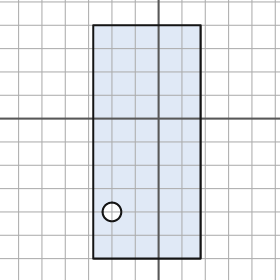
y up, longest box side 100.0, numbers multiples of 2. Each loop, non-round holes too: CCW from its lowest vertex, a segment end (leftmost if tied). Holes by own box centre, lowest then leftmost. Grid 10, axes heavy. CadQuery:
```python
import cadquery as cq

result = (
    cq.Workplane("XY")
    .moveTo(-28.0, -60.0)
    .lineTo(18.0, -60.0)
    .lineTo(18.0, 40.0)
    .lineTo(-28.0, 40.0)
    .close()
    .moveTo(-20.0, -40.0)
    .circle(4.0)
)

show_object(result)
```